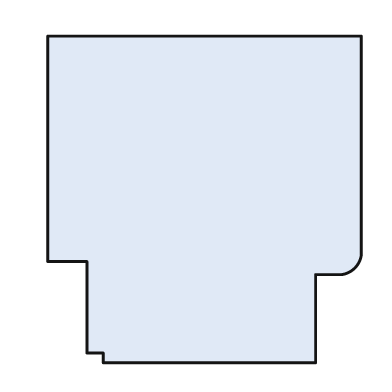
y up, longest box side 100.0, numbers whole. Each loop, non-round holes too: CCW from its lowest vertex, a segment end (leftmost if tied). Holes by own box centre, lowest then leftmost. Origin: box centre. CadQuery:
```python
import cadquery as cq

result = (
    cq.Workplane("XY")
    .moveTo(-31.0, -50.0)
    .lineTo(34.0, -50.0)
    .lineTo(34.0, -23.0)
    .lineTo(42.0, -23.0)
    .threePointArc((46.0, -21.0), (48.0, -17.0))
    .lineTo(48.0, 50.0)
    .lineTo(-48.0, 50.0)
    .lineTo(-48.0, -19.0)
    .lineTo(-36.0, -19.0)
    .lineTo(-36.0, -47.0)
    .lineTo(-31.0, -47.0)
    .close()
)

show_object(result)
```